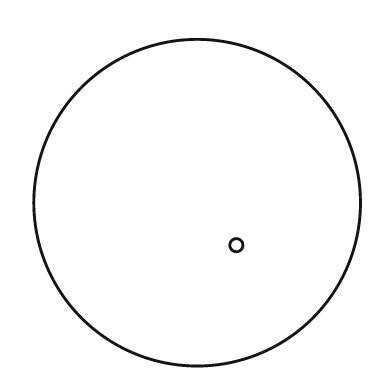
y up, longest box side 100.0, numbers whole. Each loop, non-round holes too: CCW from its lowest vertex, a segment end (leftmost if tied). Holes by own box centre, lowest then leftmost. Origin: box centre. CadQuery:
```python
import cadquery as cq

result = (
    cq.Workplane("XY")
    .moveTo(0.0, 0.0)
    .circle(50.0)
    .moveTo(12.0, -13.0)
    .circle(2.0)
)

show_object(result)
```